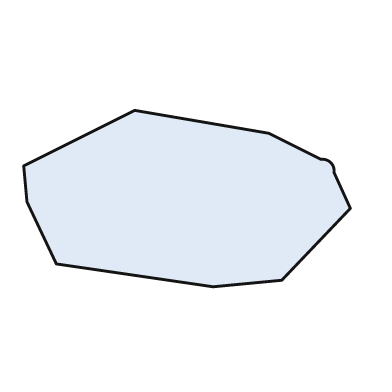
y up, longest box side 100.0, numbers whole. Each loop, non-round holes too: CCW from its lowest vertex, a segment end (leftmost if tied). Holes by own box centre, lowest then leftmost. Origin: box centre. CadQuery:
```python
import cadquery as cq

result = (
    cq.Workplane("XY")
    .moveTo(8.0, -27.0)
    .lineTo(29.0, -25.0)
    .lineTo(50.0, -3.0)
    .lineTo(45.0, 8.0)
    .threePointArc((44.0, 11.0), (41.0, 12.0))
    .lineTo(25.0, 20.0)
    .lineTo(-16.0, 27.0)
    .lineTo(-50.0, 10.0)
    .lineTo(-49.0, -1.0)
    .lineTo(-40.0, -20.0)
    .close()
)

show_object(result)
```